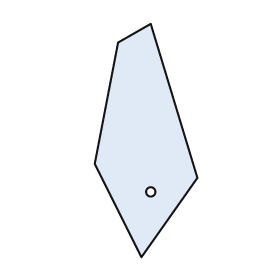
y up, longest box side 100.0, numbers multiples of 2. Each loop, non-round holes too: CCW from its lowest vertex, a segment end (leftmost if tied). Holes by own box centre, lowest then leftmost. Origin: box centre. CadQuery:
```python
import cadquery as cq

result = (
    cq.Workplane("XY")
    .moveTo(-2.0, -50.0)
    .lineTo(22.0, -16.0)
    .lineTo(2.0, 50.0)
    .lineTo(-12.0, 42.0)
    .lineTo(-22.0, -10.0)
    .close()
    .moveTo(2.0, -22.0)
    .circle(2.0)
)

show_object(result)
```